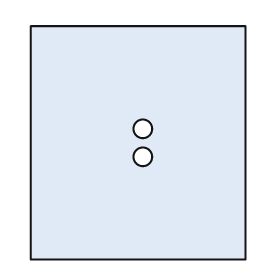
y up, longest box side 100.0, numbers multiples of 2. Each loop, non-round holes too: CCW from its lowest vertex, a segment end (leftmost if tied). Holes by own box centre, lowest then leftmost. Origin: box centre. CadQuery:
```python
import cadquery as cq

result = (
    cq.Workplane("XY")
    .moveTo(-46.0, -50.0)
    .lineTo(46.0, -50.0)
    .lineTo(46.0, 50.0)
    .lineTo(-46.0, 50.0)
    .close()
    .moveTo(2.0, -6.0)
    .circle(4.0)
    .moveTo(2.0, 6.0)
    .circle(4.0)
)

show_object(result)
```